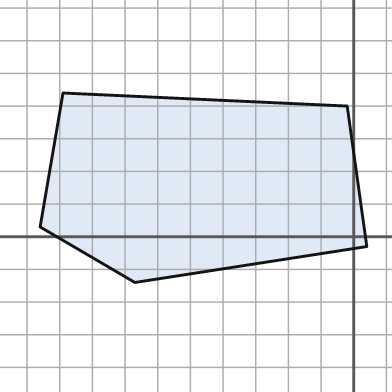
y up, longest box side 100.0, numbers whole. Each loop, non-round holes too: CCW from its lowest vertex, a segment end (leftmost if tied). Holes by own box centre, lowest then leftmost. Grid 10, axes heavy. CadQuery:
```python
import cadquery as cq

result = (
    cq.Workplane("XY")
    .moveTo(-67.0, -14.0)
    .lineTo(4.0, -3.0)
    .lineTo(-2.0, 40.0)
    .lineTo(-89.0, 44.0)
    .lineTo(-96.0, 3.0)
    .close()
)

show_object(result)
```